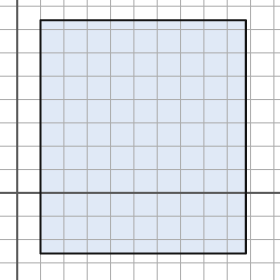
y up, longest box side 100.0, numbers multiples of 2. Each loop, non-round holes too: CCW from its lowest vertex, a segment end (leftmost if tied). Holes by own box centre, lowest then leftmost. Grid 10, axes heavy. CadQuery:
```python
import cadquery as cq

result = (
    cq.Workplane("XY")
    .moveTo(10.0, -26.0)
    .lineTo(98.0, -26.0)
    .lineTo(98.0, 74.0)
    .lineTo(10.0, 74.0)
    .close()
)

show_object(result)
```